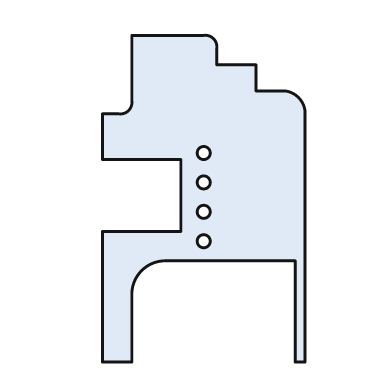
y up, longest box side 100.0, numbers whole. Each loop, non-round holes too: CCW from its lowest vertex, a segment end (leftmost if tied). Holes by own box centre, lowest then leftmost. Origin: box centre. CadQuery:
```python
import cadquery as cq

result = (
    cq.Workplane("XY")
    .moveTo(-31.0, -50.0)
    .lineTo(-22.0, -50.0)
    .lineTo(-22.0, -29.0)
    .threePointArc((-19.0, -22.0), (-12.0, -19.0))
    .lineTo(28.0, -19.0)
    .lineTo(28.0, -50.0)
    .lineTo(31.0, -50.0)
    .lineTo(31.0, 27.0)
    .threePointArc((29.0, 31.0), (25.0, 33.0))
    .lineTo(16.0, 33.0)
    .lineTo(16.0, 41.0)
    .lineTo(4.0, 41.0)
    .lineTo(4.0, 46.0)
    .threePointArc((3.0, 49.0), (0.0, 50.0))
    .lineTo(-22.0, 50.0)
    .lineTo(-22.0, 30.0)
    .threePointArc((-23.0, 27.0), (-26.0, 26.0))
    .lineTo(-31.0, 26.0)
    .lineTo(-31.0, 12.0)
    .lineTo(-7.0, 12.0)
    .lineTo(-7.0, -10.0)
    .lineTo(-31.0, -10.0)
    .close()
    .moveTo(0.0, -13.0)
    .circle(2.0)
    .moveTo(0.0, -4.0)
    .circle(2.0)
    .moveTo(0.0, 5.0)
    .circle(2.0)
    .moveTo(0.0, 14.0)
    .circle(2.0)
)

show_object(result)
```